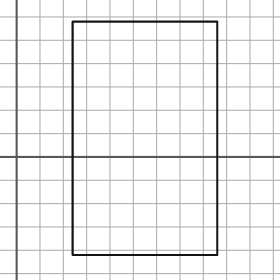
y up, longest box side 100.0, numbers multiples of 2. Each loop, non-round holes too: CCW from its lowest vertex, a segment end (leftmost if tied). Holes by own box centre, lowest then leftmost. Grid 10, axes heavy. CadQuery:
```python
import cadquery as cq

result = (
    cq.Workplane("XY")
    .moveTo(24.0, -42.0)
    .lineTo(86.0, -42.0)
    .lineTo(86.0, 58.0)
    .lineTo(24.0, 58.0)
    .close()
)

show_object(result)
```